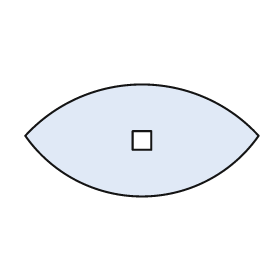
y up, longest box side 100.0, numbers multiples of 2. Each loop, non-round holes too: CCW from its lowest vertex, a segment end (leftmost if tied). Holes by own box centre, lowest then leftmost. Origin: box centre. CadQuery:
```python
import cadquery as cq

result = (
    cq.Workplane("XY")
    .moveTo(-50.0, 2.0)
    .threePointArc((0.0, -24.0), (50.0, 2.0))
    .threePointArc((0.0, 24.0), (-50.0, 2.0))
    .close()
    .moveTo(-4.0, -4.0)
    .lineTo(4.0, -4.0)
    .lineTo(4.0, 4.0)
    .lineTo(-4.0, 4.0)
    .close()
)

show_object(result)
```